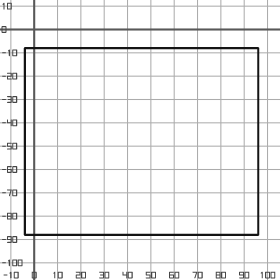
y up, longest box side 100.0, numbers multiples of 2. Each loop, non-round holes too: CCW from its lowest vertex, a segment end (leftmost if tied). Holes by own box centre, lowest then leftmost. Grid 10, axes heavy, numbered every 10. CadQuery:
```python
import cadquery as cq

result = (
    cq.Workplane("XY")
    .moveTo(-4.0, -88.0)
    .lineTo(96.0, -88.0)
    .lineTo(96.0, -8.0)
    .lineTo(-4.0, -8.0)
    .close()
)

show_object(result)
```